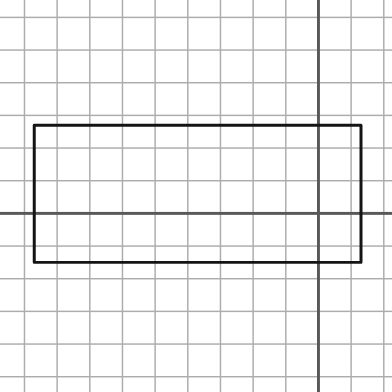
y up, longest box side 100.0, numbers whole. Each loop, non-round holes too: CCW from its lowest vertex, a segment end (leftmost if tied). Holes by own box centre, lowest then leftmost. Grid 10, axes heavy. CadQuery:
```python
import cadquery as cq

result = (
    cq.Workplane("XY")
    .moveTo(-87.0, -15.0)
    .lineTo(13.0, -15.0)
    .lineTo(13.0, 27.0)
    .lineTo(-87.0, 27.0)
    .close()
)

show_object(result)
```